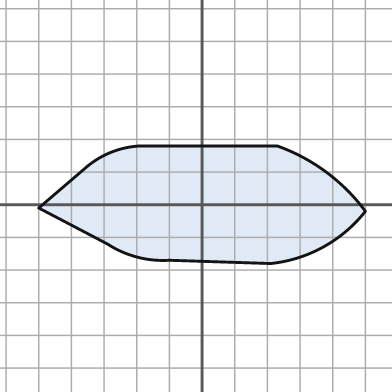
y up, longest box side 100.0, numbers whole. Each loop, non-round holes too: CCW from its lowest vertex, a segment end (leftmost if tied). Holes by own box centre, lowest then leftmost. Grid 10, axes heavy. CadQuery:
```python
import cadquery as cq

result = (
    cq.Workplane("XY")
    .moveTo(21.0, -18.0)
    .threePointArc((37.0, -13.0), (50.0, -2.0))
    .threePointArc((38.0, 10.0), (23.0, 18.0))
    .lineTo(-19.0, 18.0)
    .threePointArc((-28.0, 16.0), (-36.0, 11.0))
    .lineTo(-50.0, -1.0)
    .lineTo(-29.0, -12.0)
    .threePointArc((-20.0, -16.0), (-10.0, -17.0))
    .close()
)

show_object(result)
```